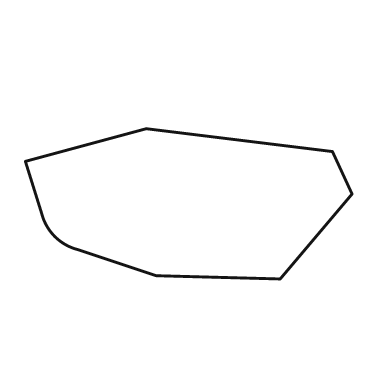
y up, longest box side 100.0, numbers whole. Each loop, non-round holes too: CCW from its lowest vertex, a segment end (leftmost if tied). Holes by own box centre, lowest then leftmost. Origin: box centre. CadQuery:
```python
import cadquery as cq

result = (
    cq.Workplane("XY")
    .moveTo(28.0, -23.0)
    .lineTo(50.0, 3.0)
    .lineTo(44.0, 16.0)
    .lineTo(-13.0, 23.0)
    .lineTo(-50.0, 13.0)
    .lineTo(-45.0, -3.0)
    .threePointArc((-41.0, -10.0), (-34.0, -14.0))
    .lineTo(-10.0, -22.0)
    .close()
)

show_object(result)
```